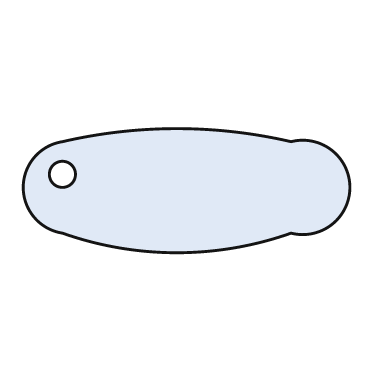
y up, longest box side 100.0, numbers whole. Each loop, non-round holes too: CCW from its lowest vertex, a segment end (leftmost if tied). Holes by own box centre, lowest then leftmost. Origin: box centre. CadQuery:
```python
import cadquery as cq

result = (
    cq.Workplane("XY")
    .moveTo(-38.0, -13.0)
    .threePointArc((-3.0, -19.0), (32.0, -13.0))
    .threePointArc((50.0, 1.0), (32.0, 15.0))
    .threePointArc((-3.0, 19.0), (-38.0, 15.0))
    .threePointArc((-50.0, 1.0), (-38.0, -13.0))
    .close()
    .moveTo(-38.0, 5.0)
    .circle(4.0)
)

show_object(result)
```